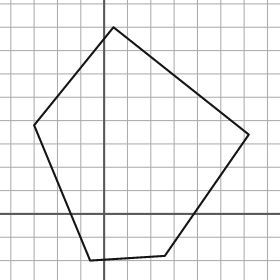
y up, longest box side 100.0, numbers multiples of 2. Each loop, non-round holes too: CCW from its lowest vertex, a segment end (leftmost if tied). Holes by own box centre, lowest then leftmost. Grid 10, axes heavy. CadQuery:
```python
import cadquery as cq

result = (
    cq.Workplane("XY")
    .moveTo(-6.0, -20.0)
    .lineTo(26.0, -18.0)
    .lineTo(62.0, 34.0)
    .lineTo(4.0, 80.0)
    .lineTo(-30.0, 38.0)
    .close()
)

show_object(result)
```